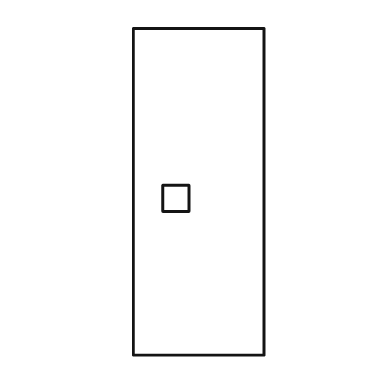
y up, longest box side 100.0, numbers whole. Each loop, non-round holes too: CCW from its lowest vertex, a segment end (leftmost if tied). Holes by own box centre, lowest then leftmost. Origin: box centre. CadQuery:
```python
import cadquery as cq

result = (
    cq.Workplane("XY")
    .moveTo(-20.0, -50.0)
    .lineTo(20.0, -50.0)
    .lineTo(20.0, 50.0)
    .lineTo(-20.0, 50.0)
    .close()
    .moveTo(-11.0, -6.0)
    .lineTo(-3.0, -6.0)
    .lineTo(-3.0, 2.0)
    .lineTo(-11.0, 2.0)
    .close()
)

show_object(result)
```